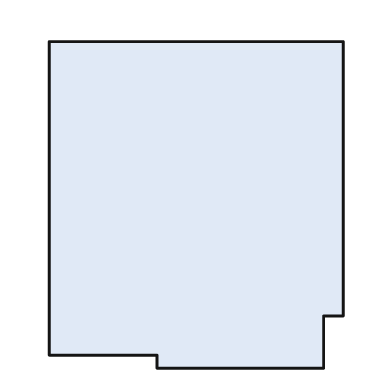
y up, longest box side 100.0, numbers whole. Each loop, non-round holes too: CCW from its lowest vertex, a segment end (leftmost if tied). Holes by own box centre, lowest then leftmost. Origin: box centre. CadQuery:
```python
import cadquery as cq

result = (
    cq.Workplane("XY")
    .moveTo(-12.0, -50.0)
    .lineTo(39.0, -50.0)
    .lineTo(39.0, -34.0)
    .lineTo(45.0, -34.0)
    .lineTo(45.0, 50.0)
    .lineTo(-45.0, 50.0)
    .lineTo(-45.0, -46.0)
    .lineTo(-12.0, -46.0)
    .close()
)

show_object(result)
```